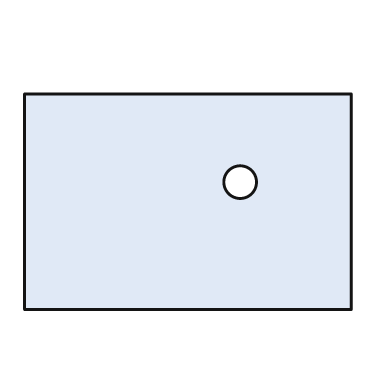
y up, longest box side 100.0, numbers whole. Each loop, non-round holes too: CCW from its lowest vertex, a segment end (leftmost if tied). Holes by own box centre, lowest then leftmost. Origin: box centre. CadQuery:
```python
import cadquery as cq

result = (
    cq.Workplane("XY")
    .moveTo(-50.0, -33.0)
    .lineTo(50.0, -33.0)
    .lineTo(50.0, 33.0)
    .lineTo(-50.0, 33.0)
    .close()
    .moveTo(16.0, 6.0)
    .circle(5.0)
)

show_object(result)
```